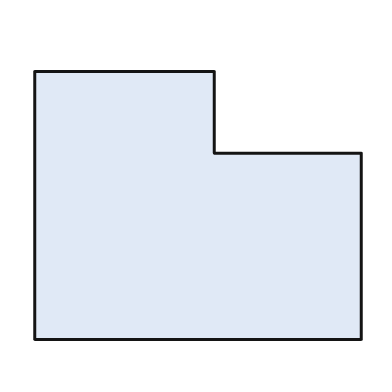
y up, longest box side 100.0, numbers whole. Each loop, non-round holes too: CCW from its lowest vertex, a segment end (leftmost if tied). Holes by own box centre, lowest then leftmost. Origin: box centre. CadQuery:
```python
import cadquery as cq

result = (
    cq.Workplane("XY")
    .moveTo(-50.0, -41.0)
    .lineTo(50.0, -41.0)
    .lineTo(50.0, 16.0)
    .lineTo(5.0, 16.0)
    .lineTo(5.0, 41.0)
    .lineTo(-50.0, 41.0)
    .close()
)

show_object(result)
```